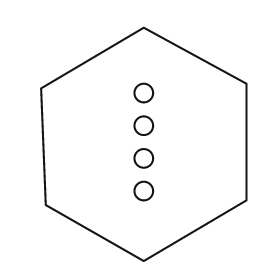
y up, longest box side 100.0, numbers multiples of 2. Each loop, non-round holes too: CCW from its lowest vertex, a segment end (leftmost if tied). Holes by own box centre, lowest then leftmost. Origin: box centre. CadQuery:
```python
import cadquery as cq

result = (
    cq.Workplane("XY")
    .moveTo(0.0, -50.0)
    .lineTo(44.0, -24.0)
    .lineTo(44.0, 26.0)
    .lineTo(0.0, 50.0)
    .lineTo(-44.0, 24.0)
    .lineTo(-42.0, -26.0)
    .close()
    .moveTo(0.0, -20.0)
    .circle(4.0)
    .moveTo(0.0, -6.0)
    .circle(4.0)
    .moveTo(0.0, 8.0)
    .circle(4.0)
    .moveTo(0.0, 22.0)
    .circle(4.0)
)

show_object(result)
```